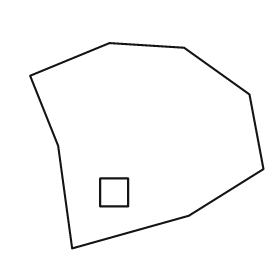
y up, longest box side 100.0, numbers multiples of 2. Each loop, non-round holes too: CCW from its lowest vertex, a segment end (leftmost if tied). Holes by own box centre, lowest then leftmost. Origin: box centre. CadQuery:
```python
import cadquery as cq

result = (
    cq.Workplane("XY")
    .moveTo(-32.0, -44.0)
    .lineTo(18.0, -30.0)
    .lineTo(50.0, -10.0)
    .lineTo(44.0, 22.0)
    .lineTo(16.0, 42.0)
    .lineTo(-16.0, 44.0)
    .lineTo(-50.0, 30.0)
    .lineTo(-38.0, 0.0)
    .close()
    .moveTo(-20.0, -26.0)
    .lineTo(-8.0, -26.0)
    .lineTo(-8.0, -14.0)
    .lineTo(-20.0, -14.0)
    .close()
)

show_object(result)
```